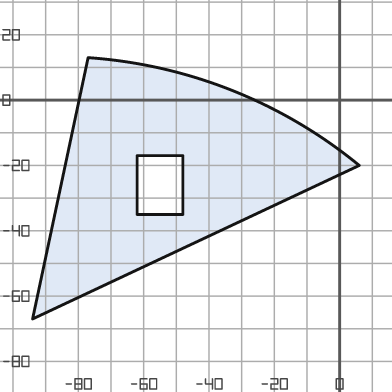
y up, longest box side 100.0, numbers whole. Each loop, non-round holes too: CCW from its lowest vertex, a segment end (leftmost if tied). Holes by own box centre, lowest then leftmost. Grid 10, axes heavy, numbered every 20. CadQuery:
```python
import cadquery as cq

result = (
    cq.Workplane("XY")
    .moveTo(-94.0, -67.0)
    .lineTo(6.0, -20.0)
    .threePointArc((-33.0, 3.0), (-77.0, 13.0))
    .close()
    .moveTo(-62.0, -35.0)
    .lineTo(-48.0, -35.0)
    .lineTo(-48.0, -17.0)
    .lineTo(-62.0, -17.0)
    .close()
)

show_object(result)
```